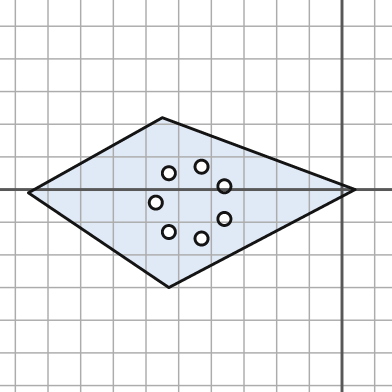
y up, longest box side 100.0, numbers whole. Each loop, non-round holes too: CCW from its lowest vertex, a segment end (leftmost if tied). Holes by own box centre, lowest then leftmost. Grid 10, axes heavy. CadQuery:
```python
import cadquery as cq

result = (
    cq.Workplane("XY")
    .moveTo(-53.0, -30.0)
    .lineTo(4.0, 0.0)
    .lineTo(-55.0, 22.0)
    .lineTo(-96.0, -1.0)
    .close()
    .moveTo(-43.0, -15.0)
    .circle(2.0)
    .moveTo(-53.0, -13.0)
    .circle(2.0)
    .moveTo(-36.0, -9.0)
    .circle(2.0)
    .moveTo(-57.0, -4.0)
    .circle(2.0)
    .moveTo(-36.0, 1.0)
    .circle(2.0)
    .moveTo(-53.0, 5.0)
    .circle(2.0)
    .moveTo(-43.0, 7.0)
    .circle(2.0)
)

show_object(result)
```